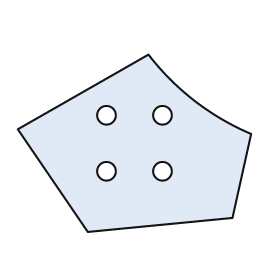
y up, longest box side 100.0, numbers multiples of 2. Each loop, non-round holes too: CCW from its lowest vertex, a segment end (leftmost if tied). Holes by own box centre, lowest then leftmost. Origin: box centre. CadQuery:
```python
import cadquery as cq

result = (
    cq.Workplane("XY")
    .moveTo(-20.0, -38.0)
    .lineTo(42.0, -32.0)
    .lineTo(50.0, 4.0)
    .threePointArc((26.0, 18.0), (6.0, 38.0))
    .lineTo(-50.0, 6.0)
    .close()
    .moveTo(-12.0, -12.0)
    .circle(4.0)
    .moveTo(12.0, -12.0)
    .circle(4.0)
    .moveTo(-12.0, 12.0)
    .circle(4.0)
    .moveTo(12.0, 12.0)
    .circle(4.0)
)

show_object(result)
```